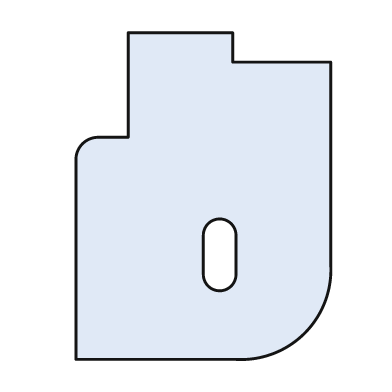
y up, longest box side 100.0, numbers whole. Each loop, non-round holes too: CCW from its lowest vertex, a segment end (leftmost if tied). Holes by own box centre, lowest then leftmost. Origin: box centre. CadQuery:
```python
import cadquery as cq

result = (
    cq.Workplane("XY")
    .moveTo(-39.0, -50.0)
    .lineTo(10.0, -50.0)
    .threePointArc((31.0, -42.0), (39.0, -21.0))
    .lineTo(39.0, 41.0)
    .lineTo(9.0, 41.0)
    .lineTo(9.0, 50.0)
    .lineTo(-23.0, 50.0)
    .lineTo(-23.0, 18.0)
    .lineTo(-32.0, 18.0)
    .threePointArc((-37.0, 16.0), (-39.0, 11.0))
    .close()
    .moveTo(0.0, -24.0)
    .threePointArc((5.0, -29.0), (10.0, -24.0))
    .lineTo(10.0, -12.0)
    .threePointArc((5.0, -7.0), (0.0, -12.0))
    .close()
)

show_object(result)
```